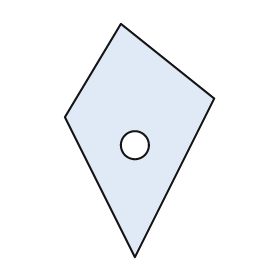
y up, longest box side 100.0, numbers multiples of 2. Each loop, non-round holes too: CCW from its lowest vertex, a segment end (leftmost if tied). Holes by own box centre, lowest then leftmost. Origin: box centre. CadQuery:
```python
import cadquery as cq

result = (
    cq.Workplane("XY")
    .moveTo(-2.0, -50.0)
    .lineTo(32.0, 18.0)
    .lineTo(-8.0, 50.0)
    .lineTo(-32.0, 10.0)
    .close()
    .moveTo(-2.0, -2.0)
    .circle(6.0)
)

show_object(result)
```